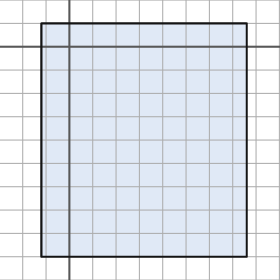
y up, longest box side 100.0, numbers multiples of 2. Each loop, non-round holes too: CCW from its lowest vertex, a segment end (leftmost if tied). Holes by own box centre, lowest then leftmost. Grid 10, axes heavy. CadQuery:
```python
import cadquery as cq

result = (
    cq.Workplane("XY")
    .moveTo(-12.0, -90.0)
    .lineTo(76.0, -90.0)
    .lineTo(76.0, 10.0)
    .lineTo(-12.0, 10.0)
    .close()
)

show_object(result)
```